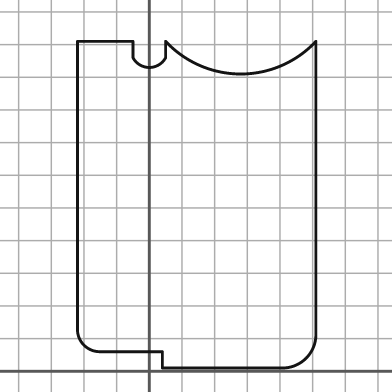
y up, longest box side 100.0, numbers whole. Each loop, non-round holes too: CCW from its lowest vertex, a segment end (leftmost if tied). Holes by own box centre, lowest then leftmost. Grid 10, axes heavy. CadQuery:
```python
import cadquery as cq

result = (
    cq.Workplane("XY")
    .moveTo(4.0, 1.0)
    .lineTo(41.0, 1.0)
    .threePointArc((48.0, 4.0), (51.0, 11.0))
    .lineTo(51.0, 101.0)
    .threePointArc((28.0, 91.0), (5.0, 101.0))
    .lineTo(5.0, 96.0)
    .threePointArc((0.0, 93.0), (-5.0, 96.0))
    .lineTo(-5.0, 101.0)
    .lineTo(-22.0, 101.0)
    .lineTo(-22.0, 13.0)
    .threePointArc((-20.0, 8.0), (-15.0, 6.0))
    .lineTo(4.0, 6.0)
    .close()
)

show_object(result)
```